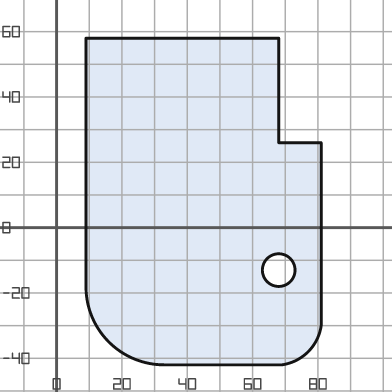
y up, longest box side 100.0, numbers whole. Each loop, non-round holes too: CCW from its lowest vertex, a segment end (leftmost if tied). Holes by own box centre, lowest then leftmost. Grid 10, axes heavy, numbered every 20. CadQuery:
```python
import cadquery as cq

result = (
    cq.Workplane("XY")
    .moveTo(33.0, -42.0)
    .lineTo(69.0, -42.0)
    .threePointArc((77.0, -38.0), (81.0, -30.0))
    .lineTo(81.0, 26.0)
    .lineTo(68.0, 26.0)
    .lineTo(68.0, 58.0)
    .lineTo(9.0, 58.0)
    .lineTo(9.0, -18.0)
    .threePointArc((16.0, -35.0), (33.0, -42.0))
    .close()
    .moveTo(68.0, -13.0)
    .circle(5.0)
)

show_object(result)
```